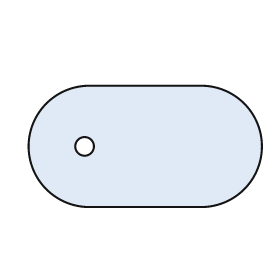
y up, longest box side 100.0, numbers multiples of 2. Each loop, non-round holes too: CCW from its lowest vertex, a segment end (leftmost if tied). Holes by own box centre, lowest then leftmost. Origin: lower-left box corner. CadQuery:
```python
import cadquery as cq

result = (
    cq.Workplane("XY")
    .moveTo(26.0, 0.0)
    .lineTo(74.0, 0.0)
    .threePointArc((100.0, 26.0), (74.0, 52.0))
    .lineTo(26.0, 52.0)
    .threePointArc((0.0, 26.0), (26.0, 0.0))
    .close()
    .moveTo(24.0, 26.0)
    .circle(4.0)
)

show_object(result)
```